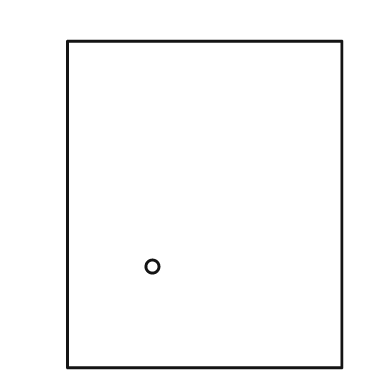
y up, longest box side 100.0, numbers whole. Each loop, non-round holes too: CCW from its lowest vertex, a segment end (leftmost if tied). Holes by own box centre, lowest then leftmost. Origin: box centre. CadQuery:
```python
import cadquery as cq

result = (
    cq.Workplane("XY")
    .moveTo(-42.0, -50.0)
    .lineTo(42.0, -50.0)
    .lineTo(42.0, 50.0)
    .lineTo(-42.0, 50.0)
    .close()
    .moveTo(-16.0, -19.0)
    .circle(2.0)
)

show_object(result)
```